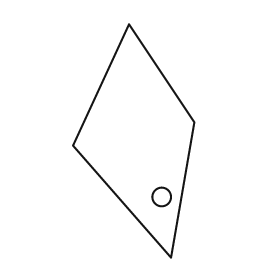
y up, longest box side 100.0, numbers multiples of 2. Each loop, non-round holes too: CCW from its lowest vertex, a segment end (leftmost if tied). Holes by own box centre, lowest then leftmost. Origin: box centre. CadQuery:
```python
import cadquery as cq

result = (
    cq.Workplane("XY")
    .moveTo(16.0, -50.0)
    .lineTo(26.0, 8.0)
    .lineTo(-2.0, 50.0)
    .lineTo(-26.0, -2.0)
    .close()
    .moveTo(12.0, -24.0)
    .circle(4.0)
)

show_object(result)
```